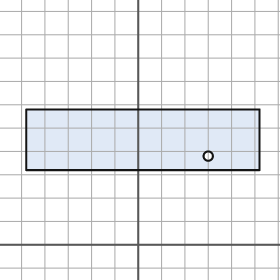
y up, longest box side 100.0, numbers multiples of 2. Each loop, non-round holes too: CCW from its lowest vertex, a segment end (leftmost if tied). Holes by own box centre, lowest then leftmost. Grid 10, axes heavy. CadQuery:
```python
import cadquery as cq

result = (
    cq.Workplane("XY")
    .moveTo(-48.0, 32.0)
    .lineTo(52.0, 32.0)
    .lineTo(52.0, 58.0)
    .lineTo(-48.0, 58.0)
    .close()
    .moveTo(30.0, 38.0)
    .circle(2.0)
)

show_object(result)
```